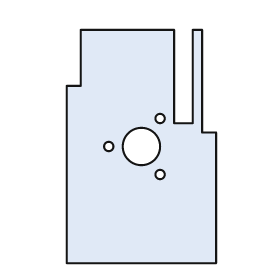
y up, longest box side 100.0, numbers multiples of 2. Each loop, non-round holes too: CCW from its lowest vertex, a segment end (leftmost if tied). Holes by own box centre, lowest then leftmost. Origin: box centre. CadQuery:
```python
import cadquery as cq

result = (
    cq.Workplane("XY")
    .moveTo(-32.0, -50.0)
    .lineTo(32.0, -50.0)
    .lineTo(32.0, 6.0)
    .lineTo(26.0, 6.0)
    .lineTo(26.0, 50.0)
    .lineTo(22.0, 50.0)
    .lineTo(22.0, 10.0)
    .lineTo(14.0, 10.0)
    .lineTo(14.0, 50.0)
    .lineTo(-26.0, 50.0)
    .lineTo(-26.0, 26.0)
    .lineTo(-32.0, 26.0)
    .close()
    .moveTo(8.0, -12.0)
    .circle(2.0)
    .moveTo(-14.0, 0.0)
    .circle(2.0)
    .moveTo(0.0, 0.0)
    .circle(8.0)
    .moveTo(8.0, 12.0)
    .circle(2.0)
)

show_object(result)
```